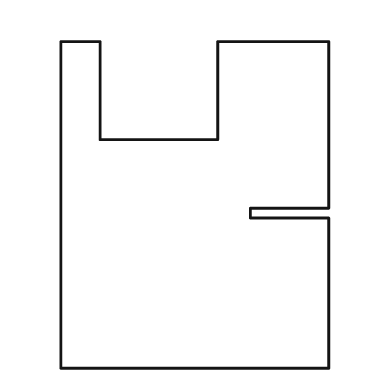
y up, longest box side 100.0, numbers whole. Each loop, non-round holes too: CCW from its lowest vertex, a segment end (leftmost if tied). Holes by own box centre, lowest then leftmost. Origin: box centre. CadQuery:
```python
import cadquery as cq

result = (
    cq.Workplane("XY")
    .moveTo(-41.0, -50.0)
    .lineTo(41.0, -50.0)
    .lineTo(41.0, -4.0)
    .lineTo(17.0, -4.0)
    .lineTo(17.0, -1.0)
    .lineTo(41.0, -1.0)
    .lineTo(41.0, 50.0)
    .lineTo(7.0, 50.0)
    .lineTo(7.0, 20.0)
    .lineTo(-29.0, 20.0)
    .lineTo(-29.0, 50.0)
    .lineTo(-41.0, 50.0)
    .close()
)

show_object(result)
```